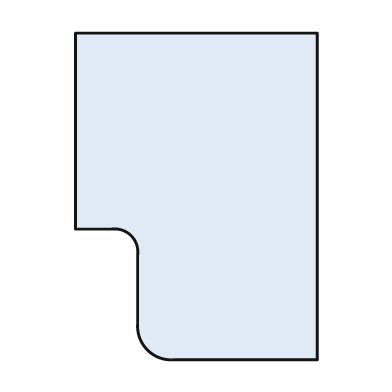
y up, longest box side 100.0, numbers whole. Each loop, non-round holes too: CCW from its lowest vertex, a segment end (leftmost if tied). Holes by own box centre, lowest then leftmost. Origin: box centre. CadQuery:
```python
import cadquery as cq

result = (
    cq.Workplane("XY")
    .moveTo(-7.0, -50.0)
    .lineTo(37.0, -50.0)
    .lineTo(37.0, 50.0)
    .lineTo(-37.0, 50.0)
    .lineTo(-37.0, -10.0)
    .lineTo(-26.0, -10.0)
    .threePointArc((-20.0, -12.0), (-18.0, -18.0))
    .lineTo(-18.0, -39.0)
    .threePointArc((-15.0, -47.0), (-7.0, -50.0))
    .close()
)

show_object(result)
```